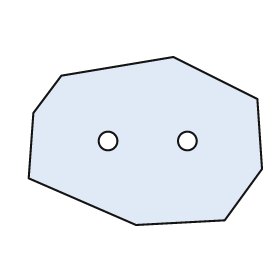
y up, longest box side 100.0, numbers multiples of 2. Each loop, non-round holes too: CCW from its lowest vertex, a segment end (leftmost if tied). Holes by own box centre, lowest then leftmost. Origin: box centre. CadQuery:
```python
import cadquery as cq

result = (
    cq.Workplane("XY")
    .moveTo(-4.0, -36.0)
    .lineTo(34.0, -34.0)
    .lineTo(50.0, -12.0)
    .lineTo(48.0, 18.0)
    .lineTo(12.0, 36.0)
    .lineTo(-36.0, 28.0)
    .lineTo(-48.0, 12.0)
    .lineTo(-50.0, -16.0)
    .close()
    .moveTo(-16.0, 0.0)
    .circle(4.0)
    .moveTo(18.0, 0.0)
    .circle(4.0)
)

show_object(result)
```